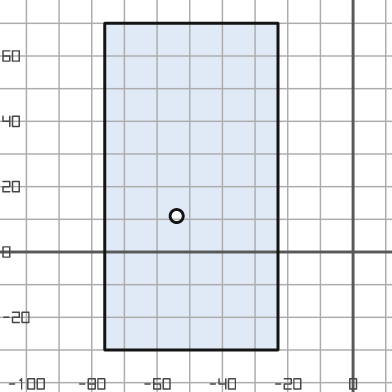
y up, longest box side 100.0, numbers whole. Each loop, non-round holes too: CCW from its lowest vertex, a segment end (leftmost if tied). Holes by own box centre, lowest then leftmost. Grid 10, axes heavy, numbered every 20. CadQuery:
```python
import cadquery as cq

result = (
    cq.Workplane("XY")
    .moveTo(-76.0, -30.0)
    .lineTo(-23.0, -30.0)
    .lineTo(-23.0, 70.0)
    .lineTo(-76.0, 70.0)
    .close()
    .moveTo(-54.0, 11.0)
    .circle(2.0)
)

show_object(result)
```